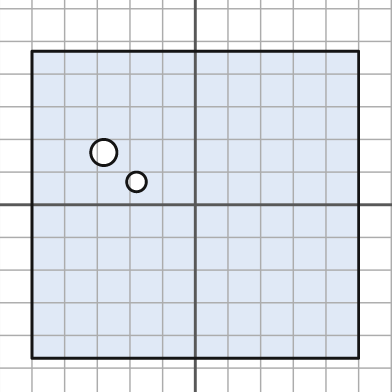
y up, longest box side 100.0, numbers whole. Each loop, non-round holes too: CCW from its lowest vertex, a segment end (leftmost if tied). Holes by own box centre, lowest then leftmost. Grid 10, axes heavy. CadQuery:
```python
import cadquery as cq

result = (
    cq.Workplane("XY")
    .moveTo(-50.0, -47.0)
    .lineTo(50.0, -47.0)
    .lineTo(50.0, 47.0)
    .lineTo(-50.0, 47.0)
    .close()
    .moveTo(-18.0, 7.0)
    .circle(3.0)
    .moveTo(-28.0, 16.0)
    .circle(4.0)
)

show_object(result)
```